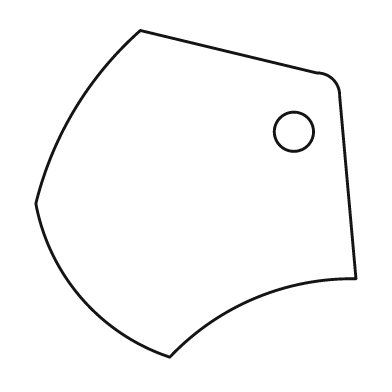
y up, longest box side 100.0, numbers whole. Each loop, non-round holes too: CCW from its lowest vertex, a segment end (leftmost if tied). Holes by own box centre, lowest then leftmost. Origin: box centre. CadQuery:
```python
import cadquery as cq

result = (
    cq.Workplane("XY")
    .moveTo(-8.0, -50.0)
    .threePointArc((18.0, -32.0), (49.0, -26.0))
    .lineTo(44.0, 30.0)
    .threePointArc((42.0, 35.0), (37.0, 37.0))
    .lineTo(-17.0, 50.0)
    .threePointArc((-37.0, 26.0), (-49.0, -3.0))
    .threePointArc((-35.0, -32.0), (-8.0, -50.0))
    .close()
    .moveTo(30.0, 19.0)
    .circle(6.0)
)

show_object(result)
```